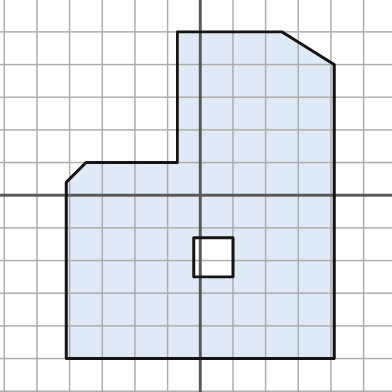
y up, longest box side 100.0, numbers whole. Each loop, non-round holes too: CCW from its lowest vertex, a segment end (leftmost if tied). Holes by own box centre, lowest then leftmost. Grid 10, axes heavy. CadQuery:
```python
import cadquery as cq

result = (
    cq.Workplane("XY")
    .moveTo(-41.0, -50.0)
    .lineTo(41.0, -50.0)
    .lineTo(41.0, 40.0)
    .lineTo(25.0, 50.0)
    .lineTo(-7.0, 50.0)
    .lineTo(-7.0, 10.0)
    .lineTo(-35.0, 10.0)
    .lineTo(-41.0, 4.0)
    .close()
    .moveTo(-2.0, -25.0)
    .lineTo(10.0, -25.0)
    .lineTo(10.0, -13.0)
    .lineTo(-2.0, -13.0)
    .close()
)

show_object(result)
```